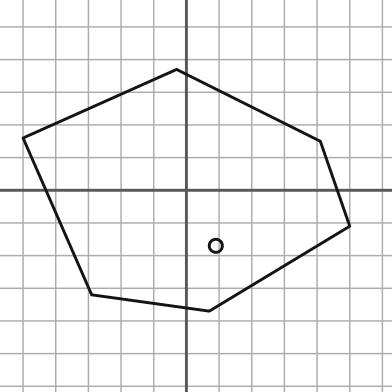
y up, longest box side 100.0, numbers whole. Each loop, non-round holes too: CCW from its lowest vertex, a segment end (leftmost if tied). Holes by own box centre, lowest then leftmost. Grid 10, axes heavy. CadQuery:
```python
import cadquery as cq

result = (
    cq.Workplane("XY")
    .moveTo(7.0, -37.0)
    .lineTo(50.0, -11.0)
    .lineTo(41.0, 15.0)
    .lineTo(-3.0, 37.0)
    .lineTo(-50.0, 16.0)
    .lineTo(-29.0, -32.0)
    .close()
    .moveTo(9.0, -17.0)
    .circle(2.0)
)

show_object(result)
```